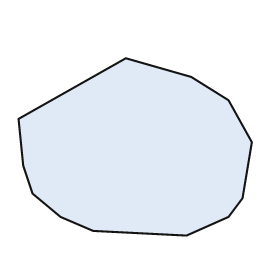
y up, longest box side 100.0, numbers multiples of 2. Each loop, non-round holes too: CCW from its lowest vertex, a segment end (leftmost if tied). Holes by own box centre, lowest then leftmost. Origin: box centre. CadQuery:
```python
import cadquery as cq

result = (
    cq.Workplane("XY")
    .moveTo(22.0, -38.0)
    .lineTo(40.0, -30.0)
    .lineTo(46.0, -22.0)
    .lineTo(50.0, 2.0)
    .lineTo(40.0, 20.0)
    .lineTo(24.0, 30.0)
    .lineTo(-4.0, 38.0)
    .lineTo(-50.0, 12.0)
    .lineTo(-48.0, -8.0)
    .lineTo(-44.0, -20.0)
    .lineTo(-32.0, -30.0)
    .lineTo(-18.0, -36.0)
    .close()
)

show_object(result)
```